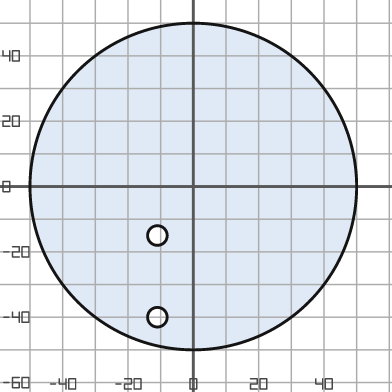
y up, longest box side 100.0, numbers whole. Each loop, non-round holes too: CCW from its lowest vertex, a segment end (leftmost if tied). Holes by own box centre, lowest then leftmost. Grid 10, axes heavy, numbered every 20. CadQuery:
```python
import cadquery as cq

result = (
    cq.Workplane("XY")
    .moveTo(0.0, 0.0)
    .circle(50.0)
    .moveTo(-11.0, -40.0)
    .circle(3.0)
    .moveTo(-11.0, -15.0)
    .circle(3.0)
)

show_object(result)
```